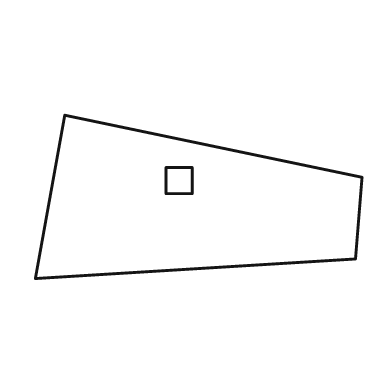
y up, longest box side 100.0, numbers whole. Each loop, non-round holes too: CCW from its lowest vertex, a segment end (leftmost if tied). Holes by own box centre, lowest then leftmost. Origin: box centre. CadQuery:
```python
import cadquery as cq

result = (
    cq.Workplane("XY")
    .moveTo(-50.0, -25.0)
    .lineTo(48.0, -19.0)
    .lineTo(50.0, 6.0)
    .lineTo(-41.0, 25.0)
    .close()
    .moveTo(-10.0, 1.0)
    .lineTo(-2.0, 1.0)
    .lineTo(-2.0, 9.0)
    .lineTo(-10.0, 9.0)
    .close()
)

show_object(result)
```